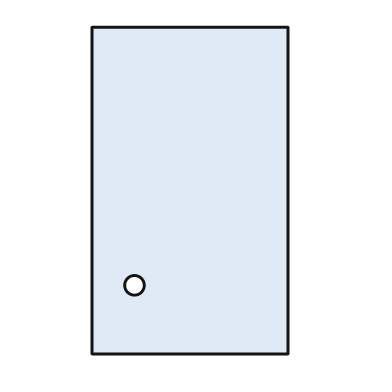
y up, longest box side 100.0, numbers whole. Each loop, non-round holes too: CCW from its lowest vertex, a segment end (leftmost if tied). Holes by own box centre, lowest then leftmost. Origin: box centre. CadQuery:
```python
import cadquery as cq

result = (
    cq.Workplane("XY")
    .moveTo(-30.0, -50.0)
    .lineTo(30.0, -50.0)
    .lineTo(30.0, 50.0)
    .lineTo(-30.0, 50.0)
    .close()
    .moveTo(-17.0, -29.0)
    .circle(3.0)
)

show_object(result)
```